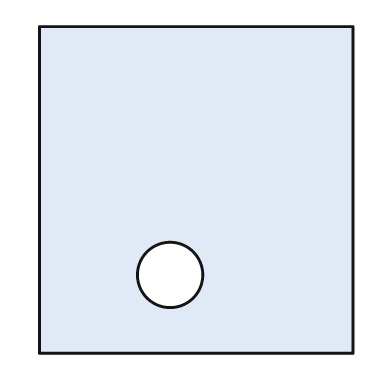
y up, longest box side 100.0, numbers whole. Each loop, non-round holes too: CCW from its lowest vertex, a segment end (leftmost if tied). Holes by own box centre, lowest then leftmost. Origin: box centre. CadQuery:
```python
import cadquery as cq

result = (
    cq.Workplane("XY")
    .moveTo(-48.0, -50.0)
    .lineTo(48.0, -50.0)
    .lineTo(48.0, 50.0)
    .lineTo(-48.0, 50.0)
    .close()
    .moveTo(-8.0, -26.0)
    .circle(10.0)
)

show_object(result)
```